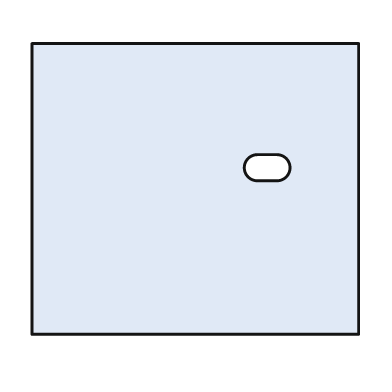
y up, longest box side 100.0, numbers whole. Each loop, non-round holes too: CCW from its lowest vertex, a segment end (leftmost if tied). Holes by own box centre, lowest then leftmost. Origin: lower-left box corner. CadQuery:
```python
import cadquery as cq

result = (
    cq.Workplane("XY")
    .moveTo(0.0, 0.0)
    .lineTo(100.0, 0.0)
    .lineTo(100.0, 89.0)
    .lineTo(0.0, 89.0)
    .close()
    .moveTo(69.0, 47.0)
    .lineTo(75.0, 47.0)
    .threePointArc((79.0, 51.0), (75.0, 55.0))
    .lineTo(69.0, 55.0)
    .threePointArc((65.0, 51.0), (69.0, 47.0))
    .close()
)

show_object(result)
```